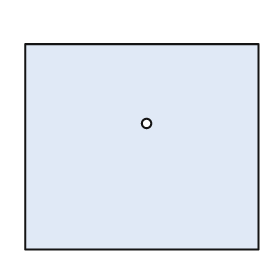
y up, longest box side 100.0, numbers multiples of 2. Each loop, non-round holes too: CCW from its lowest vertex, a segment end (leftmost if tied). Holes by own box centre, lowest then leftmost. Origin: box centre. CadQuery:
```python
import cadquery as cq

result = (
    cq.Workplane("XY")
    .moveTo(-50.0, -44.0)
    .lineTo(50.0, -44.0)
    .lineTo(50.0, 44.0)
    .lineTo(-50.0, 44.0)
    .close()
    .moveTo(2.0, 10.0)
    .circle(2.0)
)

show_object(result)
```